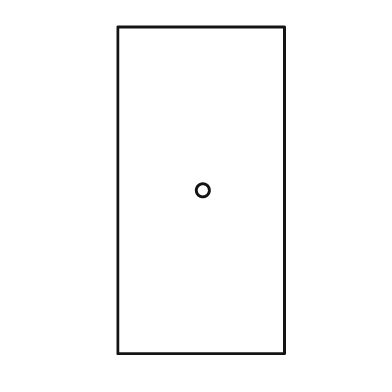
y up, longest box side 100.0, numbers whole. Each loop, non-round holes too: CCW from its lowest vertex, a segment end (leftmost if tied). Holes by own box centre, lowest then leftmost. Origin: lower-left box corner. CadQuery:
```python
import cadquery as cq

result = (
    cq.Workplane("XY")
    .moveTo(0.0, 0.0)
    .lineTo(51.0, 0.0)
    .lineTo(51.0, 100.0)
    .lineTo(0.0, 100.0)
    .close()
    .moveTo(26.0, 50.0)
    .circle(2.0)
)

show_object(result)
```